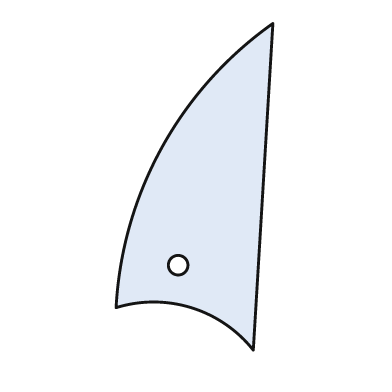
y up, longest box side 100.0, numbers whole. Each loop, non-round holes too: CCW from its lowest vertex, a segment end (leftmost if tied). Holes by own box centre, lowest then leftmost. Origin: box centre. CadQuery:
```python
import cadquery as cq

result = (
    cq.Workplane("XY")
    .moveTo(18.0, -50.0)
    .lineTo(24.0, 50.0)
    .threePointArc((-10.0, 12.0), (-24.0, -37.0))
    .threePointArc((-1.0, -37.0), (18.0, -50.0))
    .close()
    .moveTo(-5.0, -24.0)
    .circle(3.0)
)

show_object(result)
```